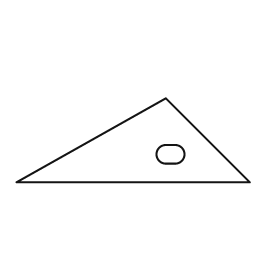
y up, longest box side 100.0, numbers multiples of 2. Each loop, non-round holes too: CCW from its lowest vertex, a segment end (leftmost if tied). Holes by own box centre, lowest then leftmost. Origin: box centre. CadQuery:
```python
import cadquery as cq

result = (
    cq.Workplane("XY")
    .moveTo(-50.0, -18.0)
    .lineTo(50.0, -18.0)
    .lineTo(14.0, 18.0)
    .close()
    .moveTo(14.0, -10.0)
    .lineTo(18.0, -10.0)
    .threePointArc((22.0, -6.0), (18.0, -2.0))
    .lineTo(14.0, -2.0)
    .threePointArc((10.0, -6.0), (14.0, -10.0))
    .close()
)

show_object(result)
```